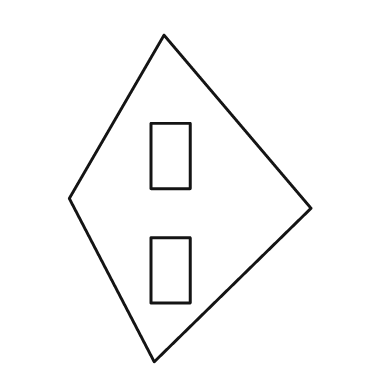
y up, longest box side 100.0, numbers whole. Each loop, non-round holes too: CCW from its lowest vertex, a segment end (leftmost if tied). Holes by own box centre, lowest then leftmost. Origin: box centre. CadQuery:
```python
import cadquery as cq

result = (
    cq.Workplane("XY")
    .moveTo(-11.0, -50.0)
    .lineTo(37.0, -3.0)
    .lineTo(-8.0, 50.0)
    .lineTo(-37.0, 0.0)
    .close()
    .moveTo(-12.0, -32.0)
    .lineTo(0.0, -32.0)
    .lineTo(0.0, -12.0)
    .lineTo(-12.0, -12.0)
    .close()
    .moveTo(-12.0, 3.0)
    .lineTo(0.0, 3.0)
    .lineTo(0.0, 23.0)
    .lineTo(-12.0, 23.0)
    .close()
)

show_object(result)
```